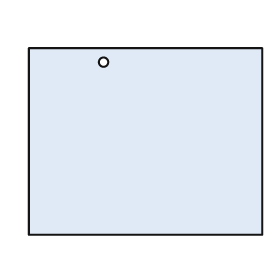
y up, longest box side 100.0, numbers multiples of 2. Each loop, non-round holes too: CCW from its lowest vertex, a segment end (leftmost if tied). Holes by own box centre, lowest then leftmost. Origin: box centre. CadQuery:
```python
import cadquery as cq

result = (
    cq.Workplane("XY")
    .moveTo(-50.0, -40.0)
    .lineTo(50.0, -40.0)
    .lineTo(50.0, 40.0)
    .lineTo(-50.0, 40.0)
    .close()
    .moveTo(-18.0, 34.0)
    .circle(2.0)
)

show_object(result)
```